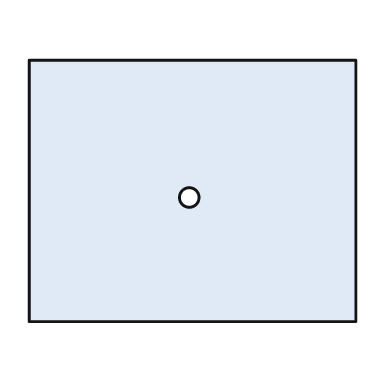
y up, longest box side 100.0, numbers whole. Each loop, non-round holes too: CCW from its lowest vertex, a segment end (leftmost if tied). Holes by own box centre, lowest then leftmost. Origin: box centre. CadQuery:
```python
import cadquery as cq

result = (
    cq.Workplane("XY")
    .moveTo(-50.0, -40.0)
    .lineTo(50.0, -40.0)
    .lineTo(50.0, 40.0)
    .lineTo(-50.0, 40.0)
    .close()
    .moveTo(-1.0, -2.0)
    .circle(3.0)
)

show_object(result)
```